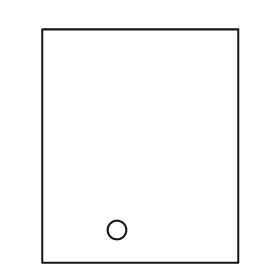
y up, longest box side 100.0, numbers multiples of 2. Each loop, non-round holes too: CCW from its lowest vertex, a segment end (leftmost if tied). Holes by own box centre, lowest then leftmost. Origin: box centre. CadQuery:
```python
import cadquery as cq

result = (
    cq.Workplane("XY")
    .moveTo(-42.0, -50.0)
    .lineTo(42.0, -50.0)
    .lineTo(42.0, 50.0)
    .lineTo(-42.0, 50.0)
    .close()
    .moveTo(-10.0, -36.0)
    .circle(4.0)
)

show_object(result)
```